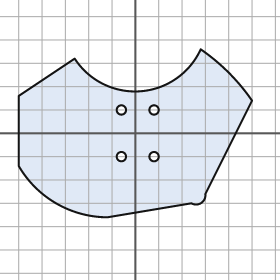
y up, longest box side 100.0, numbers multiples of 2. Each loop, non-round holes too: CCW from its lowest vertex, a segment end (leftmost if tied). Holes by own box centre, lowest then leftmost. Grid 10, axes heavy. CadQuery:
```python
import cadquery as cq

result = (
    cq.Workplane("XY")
    .moveTo(-12.0, -36.0)
    .lineTo(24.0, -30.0)
    .threePointArc((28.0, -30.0), (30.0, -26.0))
    .lineTo(50.0, 14.0)
    .threePointArc((40.0, 26.0), (28.0, 36.0))
    .threePointArc((2.0, 18.0), (-26.0, 32.0))
    .lineTo(-50.0, 16.0)
    .lineTo(-50.0, -14.0)
    .threePointArc((-34.0, -30.0), (-12.0, -36.0))
    .close()
    .moveTo(-6.0, -10.0)
    .circle(2.0)
    .moveTo(8.0, -10.0)
    .circle(2.0)
    .moveTo(-6.0, 10.0)
    .circle(2.0)
    .moveTo(8.0, 10.0)
    .circle(2.0)
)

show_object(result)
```